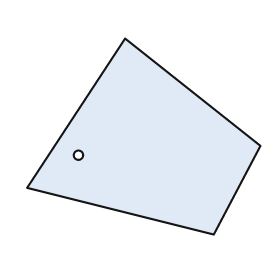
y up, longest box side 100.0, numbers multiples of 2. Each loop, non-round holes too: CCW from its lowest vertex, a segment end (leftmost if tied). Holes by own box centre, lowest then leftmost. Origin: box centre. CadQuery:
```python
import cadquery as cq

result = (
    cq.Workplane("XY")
    .moveTo(30.0, -42.0)
    .lineTo(50.0, -4.0)
    .lineTo(-8.0, 42.0)
    .lineTo(-50.0, -22.0)
    .close()
    .moveTo(-28.0, -8.0)
    .circle(2.0)
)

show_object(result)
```